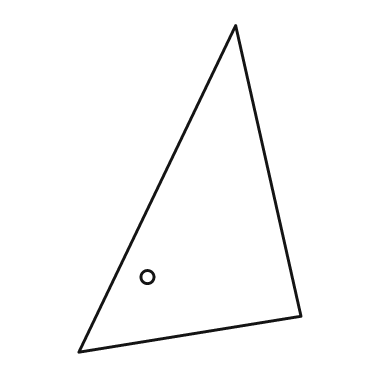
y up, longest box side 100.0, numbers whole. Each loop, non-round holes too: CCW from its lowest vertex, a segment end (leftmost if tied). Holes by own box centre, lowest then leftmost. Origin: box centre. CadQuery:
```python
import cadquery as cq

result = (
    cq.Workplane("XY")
    .moveTo(-34.0, -50.0)
    .lineTo(34.0, -39.0)
    .lineTo(14.0, 50.0)
    .close()
    .moveTo(-13.0, -27.0)
    .circle(2.0)
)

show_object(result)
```